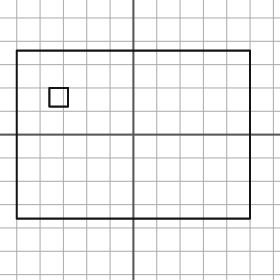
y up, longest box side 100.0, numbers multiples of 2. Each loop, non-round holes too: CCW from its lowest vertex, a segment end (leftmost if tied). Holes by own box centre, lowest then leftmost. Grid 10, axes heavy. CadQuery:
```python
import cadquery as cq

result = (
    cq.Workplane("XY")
    .moveTo(-50.0, -36.0)
    .lineTo(50.0, -36.0)
    .lineTo(50.0, 36.0)
    .lineTo(-50.0, 36.0)
    .close()
    .moveTo(-36.0, 12.0)
    .lineTo(-28.0, 12.0)
    .lineTo(-28.0, 20.0)
    .lineTo(-36.0, 20.0)
    .close()
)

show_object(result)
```